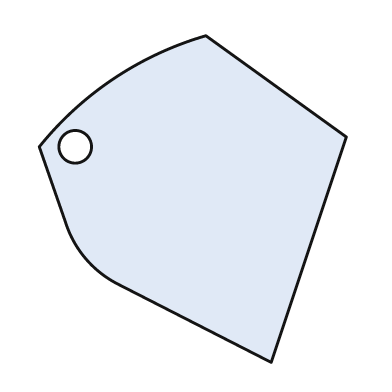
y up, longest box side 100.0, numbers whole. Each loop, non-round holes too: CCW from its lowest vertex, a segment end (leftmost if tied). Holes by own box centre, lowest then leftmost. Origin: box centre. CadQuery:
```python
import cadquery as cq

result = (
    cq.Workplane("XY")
    .moveTo(24.0, -50.0)
    .lineTo(47.0, 19.0)
    .lineTo(4.0, 50.0)
    .threePointArc((-24.0, 37.0), (-47.0, 16.0))
    .lineTo(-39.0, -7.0)
    .threePointArc((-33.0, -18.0), (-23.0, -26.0))
    .close()
    .moveTo(-36.0, 16.0)
    .circle(5.0)
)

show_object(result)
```